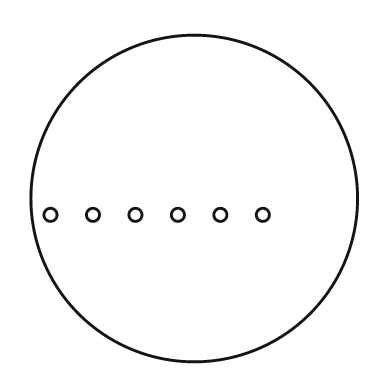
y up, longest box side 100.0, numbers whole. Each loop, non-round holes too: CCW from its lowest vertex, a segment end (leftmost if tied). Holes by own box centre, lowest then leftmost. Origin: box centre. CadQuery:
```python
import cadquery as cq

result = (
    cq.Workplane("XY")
    .moveTo(0.0, 0.0)
    .circle(50.0)
    .moveTo(-44.0, -5.0)
    .circle(2.0)
    .moveTo(-31.0, -5.0)
    .circle(2.0)
    .moveTo(-18.0, -5.0)
    .circle(2.0)
    .moveTo(-5.0, -5.0)
    .circle(2.0)
    .moveTo(8.0, -5.0)
    .circle(2.0)
    .moveTo(21.0, -5.0)
    .circle(2.0)
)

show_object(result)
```